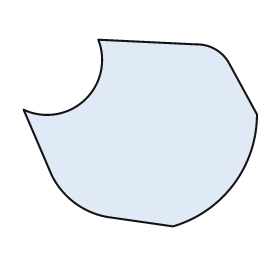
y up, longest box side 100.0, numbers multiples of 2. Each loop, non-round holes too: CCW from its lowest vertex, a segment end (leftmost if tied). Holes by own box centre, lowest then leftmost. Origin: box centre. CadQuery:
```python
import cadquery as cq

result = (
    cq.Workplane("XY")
    .moveTo(14.0, -40.0)
    .threePointArc((40.0, -22.0), (50.0, 8.0))
    .lineTo(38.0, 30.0)
    .threePointArc((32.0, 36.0), (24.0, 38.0))
    .lineTo(-18.0, 40.0)
    .threePointArc((-24.0, 14.0), (-50.0, 10.0))
    .lineTo(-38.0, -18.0)
    .threePointArc((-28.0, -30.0), (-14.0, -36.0))
    .close()
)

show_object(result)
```